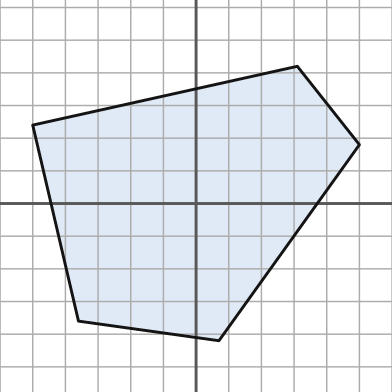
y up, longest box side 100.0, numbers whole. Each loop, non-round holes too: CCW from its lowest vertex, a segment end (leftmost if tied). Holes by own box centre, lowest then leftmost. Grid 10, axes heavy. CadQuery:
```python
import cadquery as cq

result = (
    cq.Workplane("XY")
    .moveTo(7.0, -42.0)
    .lineTo(50.0, 18.0)
    .lineTo(31.0, 42.0)
    .lineTo(-50.0, 24.0)
    .lineTo(-36.0, -36.0)
    .close()
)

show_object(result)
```